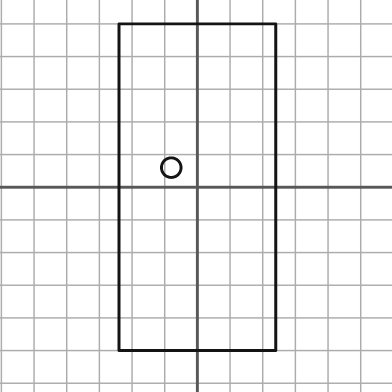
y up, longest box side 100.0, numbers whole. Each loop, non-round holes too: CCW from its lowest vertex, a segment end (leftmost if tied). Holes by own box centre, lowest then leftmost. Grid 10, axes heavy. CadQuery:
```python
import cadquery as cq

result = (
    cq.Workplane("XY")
    .moveTo(-24.0, -50.0)
    .lineTo(24.0, -50.0)
    .lineTo(24.0, 50.0)
    .lineTo(-24.0, 50.0)
    .close()
    .moveTo(-8.0, 6.0)
    .circle(3.0)
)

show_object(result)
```